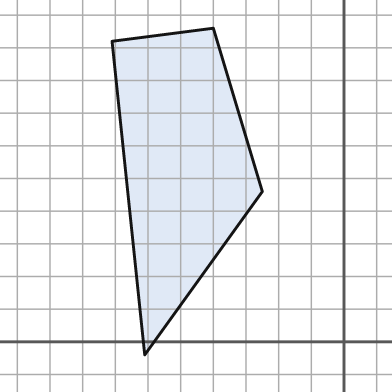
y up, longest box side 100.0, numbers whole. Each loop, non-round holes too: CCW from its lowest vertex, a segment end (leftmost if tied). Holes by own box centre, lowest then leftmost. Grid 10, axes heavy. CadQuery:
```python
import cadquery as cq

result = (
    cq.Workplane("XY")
    .moveTo(-61.0, -4.0)
    .lineTo(-25.0, 46.0)
    .lineTo(-40.0, 96.0)
    .lineTo(-71.0, 92.0)
    .close()
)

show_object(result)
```